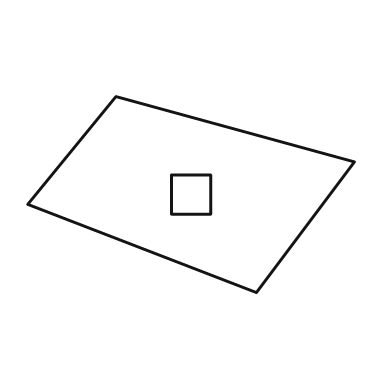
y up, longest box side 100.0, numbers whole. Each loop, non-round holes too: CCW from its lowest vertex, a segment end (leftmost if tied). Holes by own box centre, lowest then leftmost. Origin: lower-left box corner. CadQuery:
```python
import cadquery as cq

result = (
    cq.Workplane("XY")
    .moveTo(70.0, 0.0)
    .lineTo(100.0, 40.0)
    .lineTo(27.0, 60.0)
    .lineTo(0.0, 27.0)
    .close()
    .moveTo(44.0, 24.0)
    .lineTo(56.0, 24.0)
    .lineTo(56.0, 36.0)
    .lineTo(44.0, 36.0)
    .close()
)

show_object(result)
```